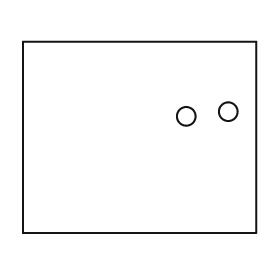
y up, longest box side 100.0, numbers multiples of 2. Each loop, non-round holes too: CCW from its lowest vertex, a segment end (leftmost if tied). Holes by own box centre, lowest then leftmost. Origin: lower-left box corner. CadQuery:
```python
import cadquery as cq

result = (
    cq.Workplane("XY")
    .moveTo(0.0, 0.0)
    .lineTo(100.0, 0.0)
    .lineTo(100.0, 82.0)
    .lineTo(0.0, 82.0)
    .close()
    .moveTo(70.0, 50.0)
    .circle(4.0)
    .moveTo(88.0, 52.0)
    .circle(4.0)
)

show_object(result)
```